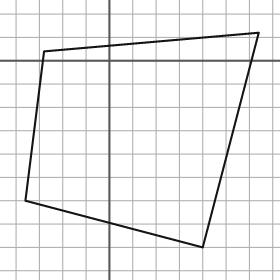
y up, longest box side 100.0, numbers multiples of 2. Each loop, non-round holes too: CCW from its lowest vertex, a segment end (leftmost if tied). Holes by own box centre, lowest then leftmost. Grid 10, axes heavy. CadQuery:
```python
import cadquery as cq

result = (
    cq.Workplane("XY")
    .moveTo(40.0, -80.0)
    .lineTo(64.0, 12.0)
    .lineTo(-28.0, 4.0)
    .lineTo(-36.0, -60.0)
    .close()
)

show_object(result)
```